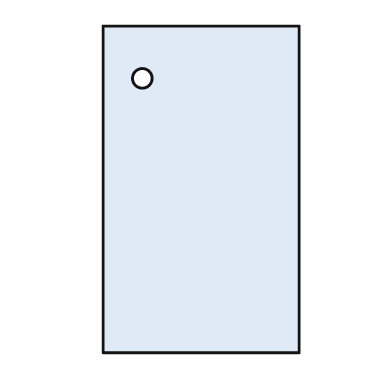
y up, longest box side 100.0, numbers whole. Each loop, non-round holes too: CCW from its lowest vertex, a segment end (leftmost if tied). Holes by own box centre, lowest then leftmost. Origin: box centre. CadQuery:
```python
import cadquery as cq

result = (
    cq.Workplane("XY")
    .moveTo(-30.0, -50.0)
    .lineTo(30.0, -50.0)
    .lineTo(30.0, 50.0)
    .lineTo(-30.0, 50.0)
    .close()
    .moveTo(-18.0, 34.0)
    .circle(3.0)
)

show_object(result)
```